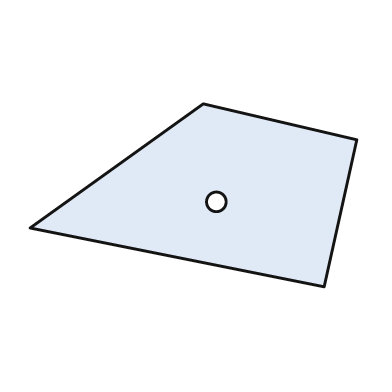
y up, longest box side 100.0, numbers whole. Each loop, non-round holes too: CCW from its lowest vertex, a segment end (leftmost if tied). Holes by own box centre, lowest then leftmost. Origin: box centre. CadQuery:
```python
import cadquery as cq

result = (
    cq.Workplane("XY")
    .moveTo(40.0, -28.0)
    .lineTo(50.0, 17.0)
    .lineTo(3.0, 28.0)
    .lineTo(-50.0, -10.0)
    .close()
    .moveTo(7.0, -2.0)
    .circle(3.0)
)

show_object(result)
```